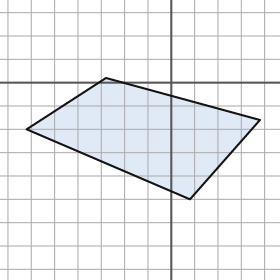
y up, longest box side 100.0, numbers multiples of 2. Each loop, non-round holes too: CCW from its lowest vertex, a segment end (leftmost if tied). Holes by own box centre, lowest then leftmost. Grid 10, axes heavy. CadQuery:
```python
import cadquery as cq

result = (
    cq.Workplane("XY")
    .moveTo(8.0, -50.0)
    .lineTo(38.0, -16.0)
    .lineTo(-28.0, 2.0)
    .lineTo(-62.0, -20.0)
    .close()
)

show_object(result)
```